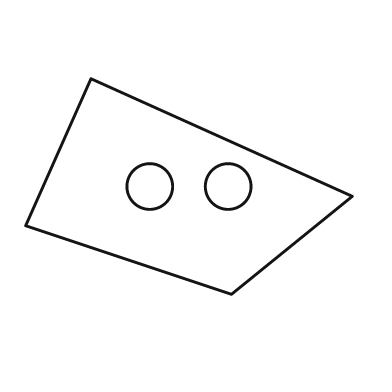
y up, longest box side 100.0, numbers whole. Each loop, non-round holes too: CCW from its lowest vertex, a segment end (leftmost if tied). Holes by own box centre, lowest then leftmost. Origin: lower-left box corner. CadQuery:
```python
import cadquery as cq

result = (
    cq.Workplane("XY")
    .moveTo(63.0, 0.0)
    .lineTo(100.0, 30.0)
    .lineTo(20.0, 66.0)
    .lineTo(0.0, 21.0)
    .close()
    .moveTo(38.0, 33.0)
    .circle(7.0)
    .moveTo(62.0, 33.0)
    .circle(7.0)
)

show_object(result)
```